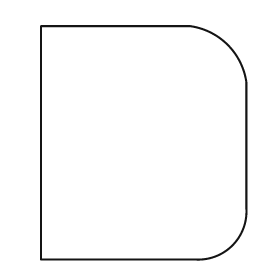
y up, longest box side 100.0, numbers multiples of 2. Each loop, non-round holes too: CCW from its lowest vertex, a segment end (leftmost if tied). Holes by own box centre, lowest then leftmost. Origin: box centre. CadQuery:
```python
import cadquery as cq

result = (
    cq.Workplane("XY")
    .moveTo(-44.0, -50.0)
    .lineTo(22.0, -50.0)
    .threePointArc((38.0, -44.0), (44.0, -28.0))
    .lineTo(44.0, 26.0)
    .threePointArc((36.0, 42.0), (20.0, 50.0))
    .lineTo(-44.0, 50.0)
    .close()
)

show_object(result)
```